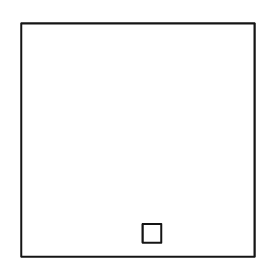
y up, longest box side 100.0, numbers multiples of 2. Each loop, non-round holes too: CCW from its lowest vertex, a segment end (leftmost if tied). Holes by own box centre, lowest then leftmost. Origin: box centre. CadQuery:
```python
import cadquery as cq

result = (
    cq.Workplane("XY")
    .moveTo(-50.0, -50.0)
    .lineTo(50.0, -50.0)
    .lineTo(50.0, 50.0)
    .lineTo(-50.0, 50.0)
    .close()
    .moveTo(2.0, -44.0)
    .lineTo(10.0, -44.0)
    .lineTo(10.0, -36.0)
    .lineTo(2.0, -36.0)
    .close()
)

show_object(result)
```